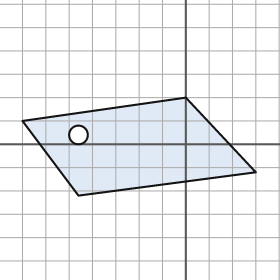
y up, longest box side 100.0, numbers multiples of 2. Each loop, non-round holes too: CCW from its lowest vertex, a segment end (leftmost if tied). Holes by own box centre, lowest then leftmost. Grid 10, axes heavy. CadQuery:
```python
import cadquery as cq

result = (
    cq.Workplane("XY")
    .moveTo(-46.0, -22.0)
    .lineTo(30.0, -12.0)
    .lineTo(0.0, 20.0)
    .lineTo(-70.0, 10.0)
    .close()
    .moveTo(-46.0, 4.0)
    .circle(4.0)
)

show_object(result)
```